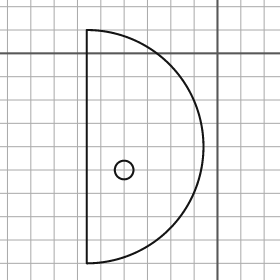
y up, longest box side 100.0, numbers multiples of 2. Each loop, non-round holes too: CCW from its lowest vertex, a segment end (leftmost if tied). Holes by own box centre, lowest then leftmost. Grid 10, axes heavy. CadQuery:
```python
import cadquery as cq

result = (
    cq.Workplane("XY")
    .moveTo(-56.0, -90.0)
    .threePointArc((-6.0, -40.0), (-56.0, 10.0))
    .close()
    .moveTo(-40.0, -50.0)
    .circle(4.0)
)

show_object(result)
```